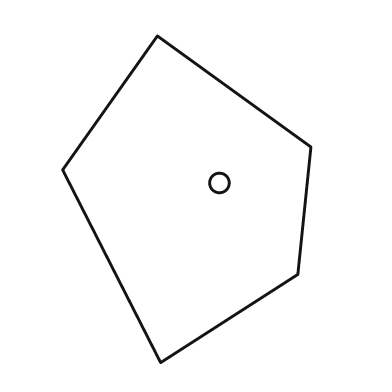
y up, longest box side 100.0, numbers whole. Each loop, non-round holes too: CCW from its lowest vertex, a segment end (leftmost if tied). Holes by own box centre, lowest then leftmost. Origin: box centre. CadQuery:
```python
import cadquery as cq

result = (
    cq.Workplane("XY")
    .moveTo(-8.0, -50.0)
    .lineTo(34.0, -23.0)
    .lineTo(38.0, 16.0)
    .lineTo(-9.0, 50.0)
    .lineTo(-38.0, 9.0)
    .close()
    .moveTo(10.0, 5.0)
    .circle(3.0)
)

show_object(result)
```